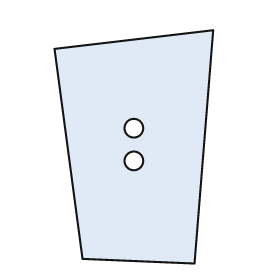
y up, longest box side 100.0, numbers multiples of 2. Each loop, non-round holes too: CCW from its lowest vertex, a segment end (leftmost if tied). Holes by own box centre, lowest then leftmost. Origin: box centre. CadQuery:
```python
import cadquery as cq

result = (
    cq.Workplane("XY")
    .moveTo(26.0, -50.0)
    .lineTo(34.0, 50.0)
    .lineTo(-34.0, 42.0)
    .lineTo(-22.0, -48.0)
    .close()
    .moveTo(0.0, -6.0)
    .circle(4.0)
    .moveTo(0.0, 8.0)
    .circle(4.0)
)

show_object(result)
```